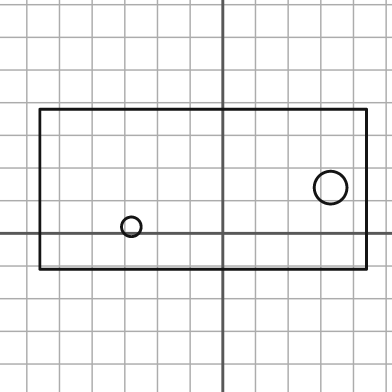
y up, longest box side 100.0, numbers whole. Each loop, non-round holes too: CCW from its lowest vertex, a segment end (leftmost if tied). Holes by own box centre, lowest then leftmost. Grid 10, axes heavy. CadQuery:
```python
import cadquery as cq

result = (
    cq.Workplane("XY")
    .moveTo(-56.0, -11.0)
    .lineTo(44.0, -11.0)
    .lineTo(44.0, 38.0)
    .lineTo(-56.0, 38.0)
    .close()
    .moveTo(-28.0, 2.0)
    .circle(3.0)
    .moveTo(33.0, 14.0)
    .circle(5.0)
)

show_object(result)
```